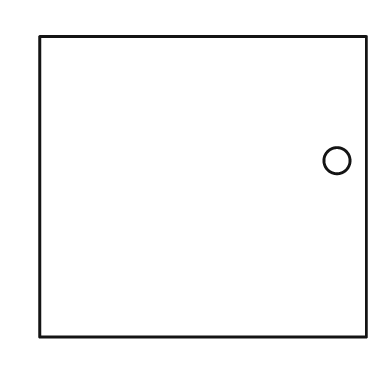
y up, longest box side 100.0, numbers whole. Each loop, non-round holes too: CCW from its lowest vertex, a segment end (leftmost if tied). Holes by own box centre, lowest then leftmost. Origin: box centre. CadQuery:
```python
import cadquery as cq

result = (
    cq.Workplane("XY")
    .moveTo(-50.0, -46.0)
    .lineTo(50.0, -46.0)
    .lineTo(50.0, 46.0)
    .lineTo(-50.0, 46.0)
    .close()
    .moveTo(41.0, 8.0)
    .circle(4.0)
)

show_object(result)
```